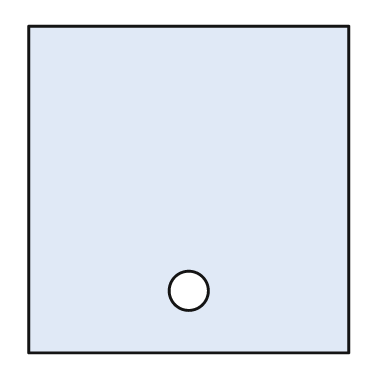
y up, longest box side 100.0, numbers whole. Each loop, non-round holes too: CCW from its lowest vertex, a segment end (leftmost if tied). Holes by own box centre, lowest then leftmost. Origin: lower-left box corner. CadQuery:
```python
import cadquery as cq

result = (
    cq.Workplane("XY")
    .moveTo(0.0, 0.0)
    .lineTo(98.0, 0.0)
    .lineTo(98.0, 100.0)
    .lineTo(0.0, 100.0)
    .close()
    .moveTo(49.0, 19.0)
    .circle(6.0)
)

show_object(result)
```